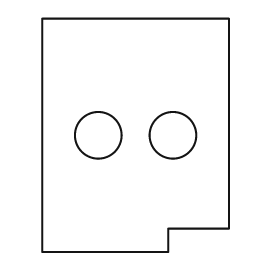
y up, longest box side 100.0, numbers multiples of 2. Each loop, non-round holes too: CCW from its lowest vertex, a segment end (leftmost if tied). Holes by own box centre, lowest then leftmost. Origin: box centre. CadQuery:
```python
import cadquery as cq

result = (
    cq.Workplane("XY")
    .moveTo(-40.0, -50.0)
    .lineTo(14.0, -50.0)
    .lineTo(14.0, -40.0)
    .lineTo(40.0, -40.0)
    .lineTo(40.0, 50.0)
    .lineTo(-40.0, 50.0)
    .close()
    .moveTo(-16.0, 0.0)
    .circle(10.0)
    .moveTo(16.0, 0.0)
    .circle(10.0)
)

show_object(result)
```